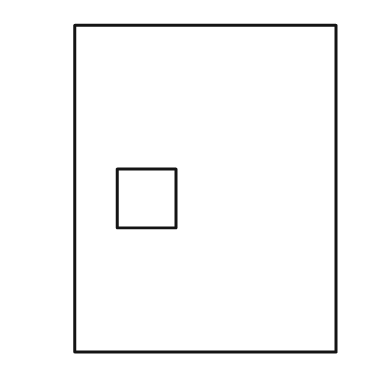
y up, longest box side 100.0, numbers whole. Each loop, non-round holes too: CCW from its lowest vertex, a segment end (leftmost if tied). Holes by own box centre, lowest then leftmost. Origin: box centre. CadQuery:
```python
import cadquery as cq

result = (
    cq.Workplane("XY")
    .moveTo(-40.0, -50.0)
    .lineTo(40.0, -50.0)
    .lineTo(40.0, 50.0)
    .lineTo(-40.0, 50.0)
    .close()
    .moveTo(-27.0, -12.0)
    .lineTo(-9.0, -12.0)
    .lineTo(-9.0, 6.0)
    .lineTo(-27.0, 6.0)
    .close()
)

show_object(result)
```